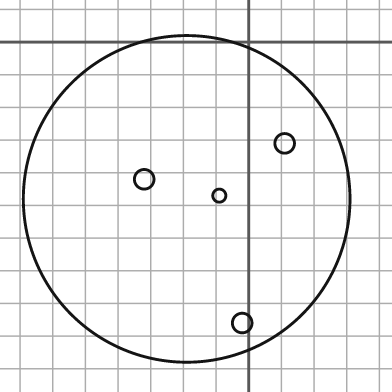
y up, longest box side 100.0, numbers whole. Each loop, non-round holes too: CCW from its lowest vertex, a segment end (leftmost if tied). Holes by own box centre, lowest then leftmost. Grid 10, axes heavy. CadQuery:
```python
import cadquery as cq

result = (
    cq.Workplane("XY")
    .moveTo(-19.0, -48.0)
    .circle(50.0)
    .moveTo(-2.0, -86.0)
    .circle(3.0)
    .moveTo(-9.0, -47.0)
    .circle(2.0)
    .moveTo(-32.0, -42.0)
    .circle(3.0)
    .moveTo(11.0, -31.0)
    .circle(3.0)
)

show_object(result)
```